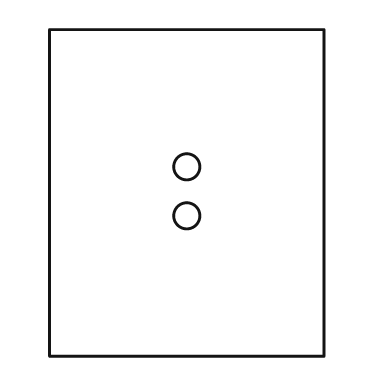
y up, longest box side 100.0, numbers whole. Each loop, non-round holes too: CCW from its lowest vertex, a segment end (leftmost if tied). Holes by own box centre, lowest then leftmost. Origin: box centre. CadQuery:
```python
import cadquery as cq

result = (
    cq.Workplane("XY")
    .moveTo(-42.0, -50.0)
    .lineTo(42.0, -50.0)
    .lineTo(42.0, 50.0)
    .lineTo(-42.0, 50.0)
    .close()
    .moveTo(0.0, -7.0)
    .circle(4.0)
    .moveTo(0.0, 8.0)
    .circle(4.0)
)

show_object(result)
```